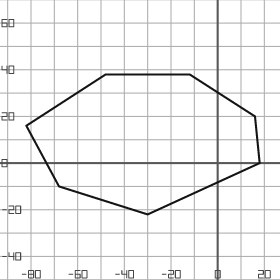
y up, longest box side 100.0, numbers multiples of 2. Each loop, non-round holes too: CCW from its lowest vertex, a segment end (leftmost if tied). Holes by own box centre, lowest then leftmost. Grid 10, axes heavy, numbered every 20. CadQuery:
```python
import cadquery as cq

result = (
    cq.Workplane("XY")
    .moveTo(-30.0, -22.0)
    .lineTo(18.0, 0.0)
    .lineTo(16.0, 20.0)
    .lineTo(-12.0, 38.0)
    .lineTo(-48.0, 38.0)
    .lineTo(-82.0, 16.0)
    .lineTo(-68.0, -10.0)
    .close()
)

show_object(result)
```